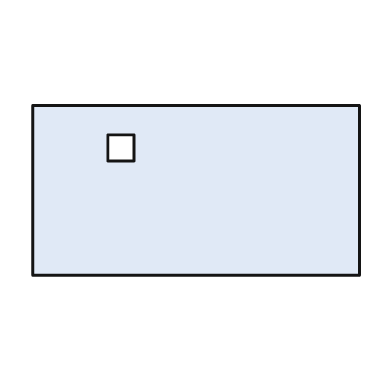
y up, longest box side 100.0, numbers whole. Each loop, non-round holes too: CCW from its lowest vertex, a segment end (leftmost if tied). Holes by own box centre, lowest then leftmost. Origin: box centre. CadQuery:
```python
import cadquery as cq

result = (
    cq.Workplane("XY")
    .moveTo(-50.0, -26.0)
    .lineTo(50.0, -26.0)
    .lineTo(50.0, 26.0)
    .lineTo(-50.0, 26.0)
    .close()
    .moveTo(-27.0, 9.0)
    .lineTo(-19.0, 9.0)
    .lineTo(-19.0, 17.0)
    .lineTo(-27.0, 17.0)
    .close()
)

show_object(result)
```